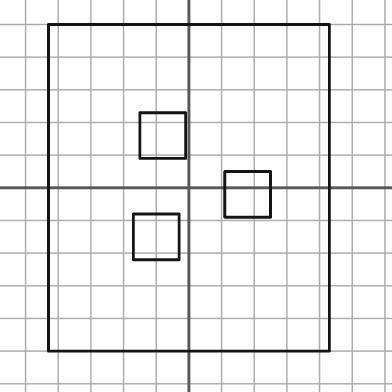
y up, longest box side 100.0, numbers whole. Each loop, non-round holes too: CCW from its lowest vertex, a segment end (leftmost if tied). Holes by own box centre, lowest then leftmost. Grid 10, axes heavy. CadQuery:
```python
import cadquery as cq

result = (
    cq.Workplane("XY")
    .moveTo(-43.0, -50.0)
    .lineTo(43.0, -50.0)
    .lineTo(43.0, 50.0)
    .lineTo(-43.0, 50.0)
    .close()
    .moveTo(-17.0, -22.0)
    .lineTo(-3.0, -22.0)
    .lineTo(-3.0, -8.0)
    .lineTo(-17.0, -8.0)
    .close()
    .moveTo(11.0, -9.0)
    .lineTo(25.0, -9.0)
    .lineTo(25.0, 5.0)
    .lineTo(11.0, 5.0)
    .close()
    .moveTo(-15.0, 9.0)
    .lineTo(-1.0, 9.0)
    .lineTo(-1.0, 23.0)
    .lineTo(-15.0, 23.0)
    .close()
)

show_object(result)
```